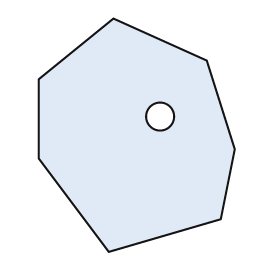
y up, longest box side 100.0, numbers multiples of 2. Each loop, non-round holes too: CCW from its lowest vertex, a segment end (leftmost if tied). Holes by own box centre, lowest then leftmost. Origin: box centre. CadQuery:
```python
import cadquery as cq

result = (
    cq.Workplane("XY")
    .moveTo(-12.0, -50.0)
    .lineTo(36.0, -36.0)
    .lineTo(42.0, -6.0)
    .lineTo(30.0, 32.0)
    .lineTo(-10.0, 50.0)
    .lineTo(-42.0, 24.0)
    .lineTo(-42.0, -10.0)
    .close()
    .moveTo(10.0, 8.0)
    .circle(6.0)
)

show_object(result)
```